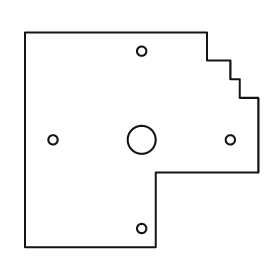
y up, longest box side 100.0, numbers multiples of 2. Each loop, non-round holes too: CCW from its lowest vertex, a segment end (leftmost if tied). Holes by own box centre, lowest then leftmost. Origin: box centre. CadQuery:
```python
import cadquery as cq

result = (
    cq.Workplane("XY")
    .moveTo(-50.0, -46.0)
    .lineTo(6.0, -46.0)
    .lineTo(6.0, -14.0)
    .lineTo(50.0, -14.0)
    .lineTo(50.0, 18.0)
    .lineTo(42.0, 18.0)
    .lineTo(42.0, 26.0)
    .lineTo(38.0, 26.0)
    .lineTo(38.0, 34.0)
    .lineTo(28.0, 34.0)
    .lineTo(28.0, 46.0)
    .lineTo(-50.0, 46.0)
    .close()
    .moveTo(0.0, -38.0)
    .circle(2.0)
    .moveTo(-38.0, 0.0)
    .circle(2.0)
    .moveTo(0.0, 0.0)
    .circle(6.0)
    .moveTo(38.0, 0.0)
    .circle(2.0)
    .moveTo(0.0, 38.0)
    .circle(2.0)
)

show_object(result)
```